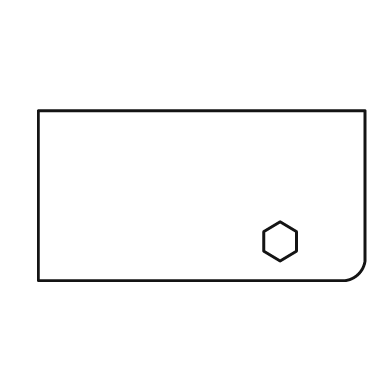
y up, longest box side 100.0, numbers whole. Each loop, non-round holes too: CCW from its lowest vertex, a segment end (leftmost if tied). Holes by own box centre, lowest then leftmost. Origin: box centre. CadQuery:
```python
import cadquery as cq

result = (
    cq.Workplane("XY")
    .moveTo(-50.0, -26.0)
    .lineTo(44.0, -26.0)
    .threePointArc((48.0, -24.0), (50.0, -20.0))
    .lineTo(50.0, 26.0)
    .lineTo(-50.0, 26.0)
    .close()
    .moveTo(24.0, -20.0)
    .lineTo(29.0, -17.0)
    .lineTo(29.0, -11.0)
    .lineTo(24.0, -8.0)
    .lineTo(19.0, -11.0)
    .lineTo(19.0, -17.0)
    .close()
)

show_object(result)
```